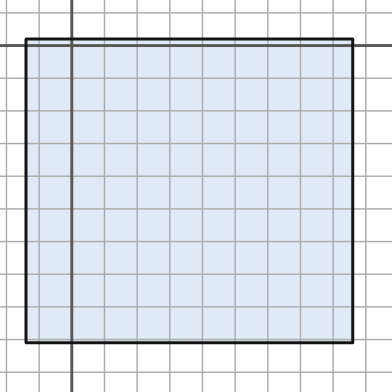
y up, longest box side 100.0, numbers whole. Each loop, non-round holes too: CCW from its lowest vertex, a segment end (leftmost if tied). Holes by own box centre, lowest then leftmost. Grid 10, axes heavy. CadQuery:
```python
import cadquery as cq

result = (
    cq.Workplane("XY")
    .moveTo(-14.0, -91.0)
    .lineTo(86.0, -91.0)
    .lineTo(86.0, 2.0)
    .lineTo(-14.0, 2.0)
    .close()
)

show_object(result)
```